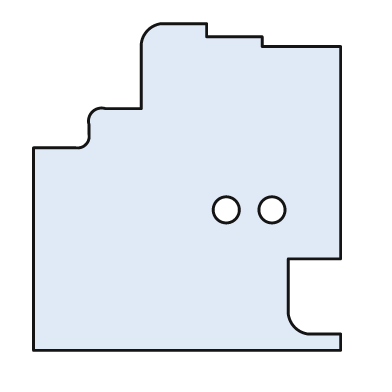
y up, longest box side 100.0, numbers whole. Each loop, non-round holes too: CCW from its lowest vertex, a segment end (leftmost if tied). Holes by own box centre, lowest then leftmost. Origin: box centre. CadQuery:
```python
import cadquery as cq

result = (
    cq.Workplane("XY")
    .moveTo(-47.0, -50.0)
    .lineTo(47.0, -50.0)
    .lineTo(47.0, -45.0)
    .lineTo(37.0, -45.0)
    .threePointArc((33.0, -43.0), (31.0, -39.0))
    .lineTo(31.0, -22.0)
    .lineTo(47.0, -22.0)
    .lineTo(47.0, 43.0)
    .lineTo(23.0, 43.0)
    .lineTo(23.0, 46.0)
    .lineTo(6.0, 46.0)
    .lineTo(6.0, 50.0)
    .lineTo(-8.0, 50.0)
    .threePointArc((-12.0, 48.0), (-14.0, 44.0))
    .lineTo(-14.0, 24.0)
    .lineTo(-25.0, 24.0)
    .threePointArc((-29.0, 23.0), (-30.0, 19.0))
    .lineTo(-30.0, 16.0)
    .threePointArc((-31.0, 13.0), (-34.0, 12.0))
    .lineTo(-47.0, 12.0)
    .close()
    .moveTo(12.0, -7.0)
    .circle(4.0)
    .moveTo(26.0, -7.0)
    .circle(4.0)
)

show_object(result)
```